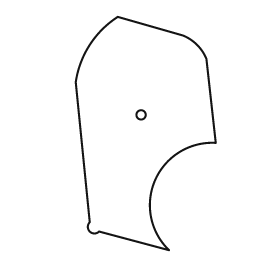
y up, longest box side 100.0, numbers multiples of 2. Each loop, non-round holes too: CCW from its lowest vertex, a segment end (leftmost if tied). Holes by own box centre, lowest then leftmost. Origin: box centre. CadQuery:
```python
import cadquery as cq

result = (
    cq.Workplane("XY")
    .moveTo(10.0, -50.0)
    .threePointArc((4.0, -20.0), (30.0, -4.0))
    .lineTo(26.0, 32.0)
    .threePointArc((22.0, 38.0), (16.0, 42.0))
    .lineTo(-12.0, 50.0)
    .threePointArc((-24.0, 38.0), (-30.0, 22.0))
    .lineTo(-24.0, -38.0)
    .threePointArc((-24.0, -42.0), (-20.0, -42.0))
    .close()
    .moveTo(-2.0, 8.0)
    .circle(2.0)
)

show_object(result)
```